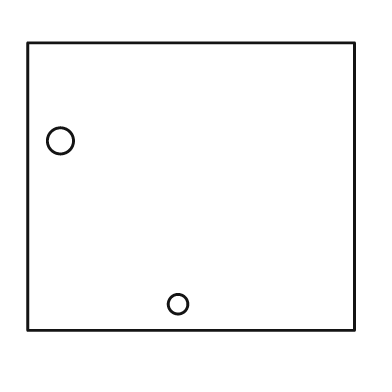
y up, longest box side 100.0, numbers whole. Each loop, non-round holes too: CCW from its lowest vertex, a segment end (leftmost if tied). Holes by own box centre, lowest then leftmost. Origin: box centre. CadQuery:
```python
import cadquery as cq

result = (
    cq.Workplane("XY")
    .moveTo(-50.0, -44.0)
    .lineTo(50.0, -44.0)
    .lineTo(50.0, 44.0)
    .lineTo(-50.0, 44.0)
    .close()
    .moveTo(-4.0, -36.0)
    .circle(3.0)
    .moveTo(-40.0, 14.0)
    .circle(4.0)
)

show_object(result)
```